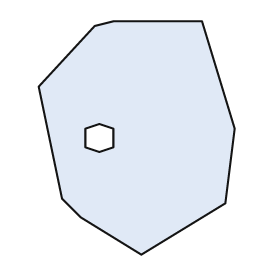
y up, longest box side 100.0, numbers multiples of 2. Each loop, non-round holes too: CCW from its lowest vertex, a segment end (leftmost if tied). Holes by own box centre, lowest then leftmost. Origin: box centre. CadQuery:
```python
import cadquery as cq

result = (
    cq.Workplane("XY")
    .moveTo(2.0, -50.0)
    .lineTo(38.0, -28.0)
    .lineTo(42.0, 4.0)
    .lineTo(28.0, 50.0)
    .lineTo(-10.0, 50.0)
    .lineTo(-18.0, 48.0)
    .lineTo(-42.0, 22.0)
    .lineTo(-32.0, -26.0)
    .lineTo(-24.0, -34.0)
    .close()
    .moveTo(-16.0, -6.0)
    .lineTo(-10.0, -4.0)
    .lineTo(-10.0, 4.0)
    .lineTo(-16.0, 6.0)
    .lineTo(-22.0, 4.0)
    .lineTo(-22.0, -4.0)
    .close()
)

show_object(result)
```